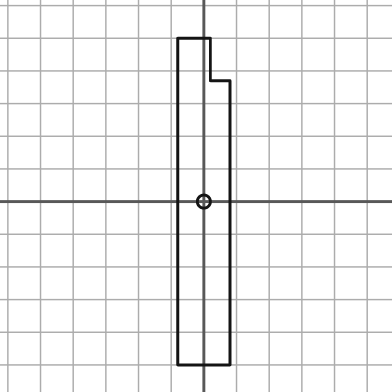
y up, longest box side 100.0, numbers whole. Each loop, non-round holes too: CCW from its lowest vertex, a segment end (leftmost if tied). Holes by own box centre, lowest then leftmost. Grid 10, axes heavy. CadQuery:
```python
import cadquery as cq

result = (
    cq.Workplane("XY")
    .moveTo(-8.0, -50.0)
    .lineTo(8.0, -50.0)
    .lineTo(8.0, 37.0)
    .lineTo(2.0, 37.0)
    .lineTo(2.0, 50.0)
    .lineTo(-8.0, 50.0)
    .close()
    .moveTo(0.0, 0.0)
    .circle(2.0)
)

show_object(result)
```